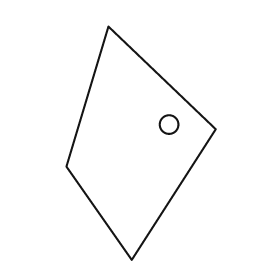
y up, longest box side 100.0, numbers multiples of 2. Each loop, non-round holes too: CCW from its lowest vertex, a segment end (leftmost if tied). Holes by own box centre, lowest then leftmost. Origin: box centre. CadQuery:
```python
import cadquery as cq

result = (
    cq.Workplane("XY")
    .moveTo(-4.0, -50.0)
    .lineTo(32.0, 6.0)
    .lineTo(-14.0, 50.0)
    .lineTo(-32.0, -10.0)
    .close()
    .moveTo(12.0, 8.0)
    .circle(4.0)
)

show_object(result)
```